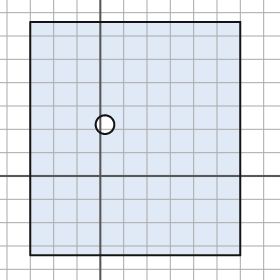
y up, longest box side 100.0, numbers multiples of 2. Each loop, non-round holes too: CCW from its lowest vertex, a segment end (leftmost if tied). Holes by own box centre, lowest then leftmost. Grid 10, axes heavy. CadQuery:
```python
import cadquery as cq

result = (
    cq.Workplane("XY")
    .moveTo(-30.0, -34.0)
    .lineTo(60.0, -34.0)
    .lineTo(60.0, 66.0)
    .lineTo(-30.0, 66.0)
    .close()
    .moveTo(2.0, 22.0)
    .circle(4.0)
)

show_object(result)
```